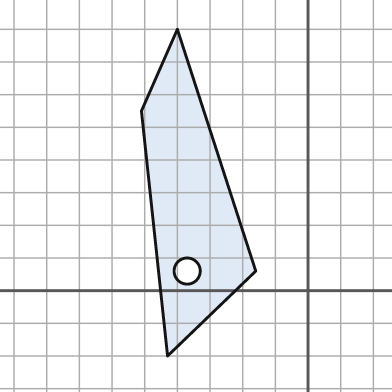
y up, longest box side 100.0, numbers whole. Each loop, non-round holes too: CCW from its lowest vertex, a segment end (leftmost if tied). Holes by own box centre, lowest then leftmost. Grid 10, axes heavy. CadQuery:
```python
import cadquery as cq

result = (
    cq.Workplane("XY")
    .moveTo(-43.0, -20.0)
    .lineTo(-16.0, 6.0)
    .lineTo(-40.0, 80.0)
    .lineTo(-51.0, 55.0)
    .close()
    .moveTo(-37.0, 6.0)
    .circle(4.0)
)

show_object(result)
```